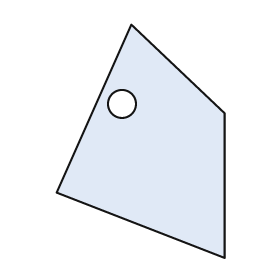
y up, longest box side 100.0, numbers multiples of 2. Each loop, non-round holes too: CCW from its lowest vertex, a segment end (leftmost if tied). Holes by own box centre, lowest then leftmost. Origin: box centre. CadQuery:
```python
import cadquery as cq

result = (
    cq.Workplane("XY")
    .moveTo(36.0, -50.0)
    .lineTo(36.0, 12.0)
    .lineTo(-4.0, 50.0)
    .lineTo(-36.0, -22.0)
    .close()
    .moveTo(-8.0, 16.0)
    .circle(6.0)
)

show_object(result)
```